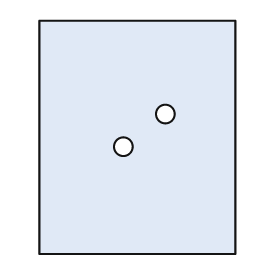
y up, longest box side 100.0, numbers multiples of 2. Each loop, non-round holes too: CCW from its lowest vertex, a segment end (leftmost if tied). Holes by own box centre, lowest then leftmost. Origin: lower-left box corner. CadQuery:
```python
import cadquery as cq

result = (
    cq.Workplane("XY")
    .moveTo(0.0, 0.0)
    .lineTo(84.0, 0.0)
    .lineTo(84.0, 100.0)
    .lineTo(0.0, 100.0)
    .close()
    .moveTo(36.0, 46.0)
    .circle(4.0)
    .moveTo(54.0, 60.0)
    .circle(4.0)
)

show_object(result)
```